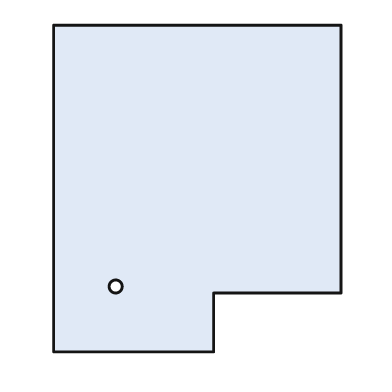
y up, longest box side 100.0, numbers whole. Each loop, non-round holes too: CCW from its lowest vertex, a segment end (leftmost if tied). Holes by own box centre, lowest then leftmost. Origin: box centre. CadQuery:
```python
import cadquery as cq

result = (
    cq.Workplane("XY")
    .moveTo(-44.0, -50.0)
    .lineTo(5.0, -50.0)
    .lineTo(5.0, -32.0)
    .lineTo(44.0, -32.0)
    .lineTo(44.0, 50.0)
    .lineTo(-44.0, 50.0)
    .close()
    .moveTo(-25.0, -30.0)
    .circle(2.0)
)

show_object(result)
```